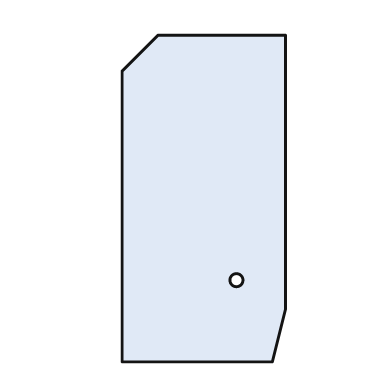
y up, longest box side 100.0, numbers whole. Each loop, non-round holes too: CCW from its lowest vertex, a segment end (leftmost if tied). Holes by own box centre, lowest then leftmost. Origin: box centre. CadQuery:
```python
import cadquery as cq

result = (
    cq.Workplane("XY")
    .moveTo(-25.0, -50.0)
    .lineTo(21.0, -50.0)
    .lineTo(25.0, -34.0)
    .lineTo(25.0, 50.0)
    .lineTo(-14.0, 50.0)
    .lineTo(-25.0, 39.0)
    .close()
    .moveTo(10.0, -25.0)
    .circle(2.0)
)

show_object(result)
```